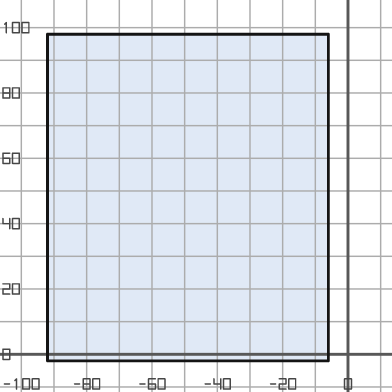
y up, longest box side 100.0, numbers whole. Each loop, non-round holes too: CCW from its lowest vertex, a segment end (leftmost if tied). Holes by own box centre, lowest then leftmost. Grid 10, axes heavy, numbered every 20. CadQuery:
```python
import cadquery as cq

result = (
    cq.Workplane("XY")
    .moveTo(-92.0, -2.0)
    .lineTo(-6.0, -2.0)
    .lineTo(-6.0, 98.0)
    .lineTo(-92.0, 98.0)
    .close()
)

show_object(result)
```